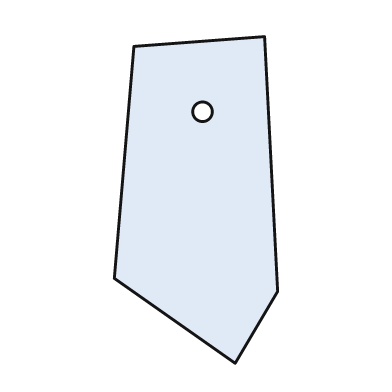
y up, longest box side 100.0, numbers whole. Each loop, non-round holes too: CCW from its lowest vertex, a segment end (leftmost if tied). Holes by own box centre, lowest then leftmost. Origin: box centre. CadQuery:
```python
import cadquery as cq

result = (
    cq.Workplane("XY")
    .moveTo(12.0, -50.0)
    .lineTo(25.0, -28.0)
    .lineTo(21.0, 50.0)
    .lineTo(-19.0, 47.0)
    .lineTo(-25.0, -24.0)
    .close()
    .moveTo(2.0, 27.0)
    .circle(3.0)
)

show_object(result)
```